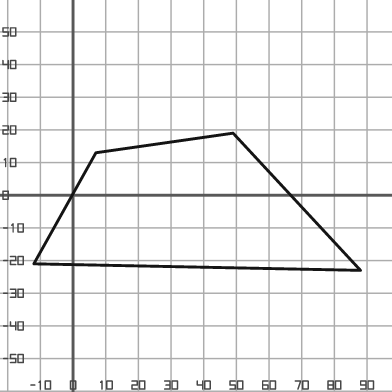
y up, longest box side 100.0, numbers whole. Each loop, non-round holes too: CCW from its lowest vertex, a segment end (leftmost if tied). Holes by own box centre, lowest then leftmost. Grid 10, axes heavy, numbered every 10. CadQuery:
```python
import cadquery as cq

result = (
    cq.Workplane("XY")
    .moveTo(88.0, -23.0)
    .lineTo(49.0, 19.0)
    .lineTo(7.0, 13.0)
    .lineTo(-12.0, -21.0)
    .close()
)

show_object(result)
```